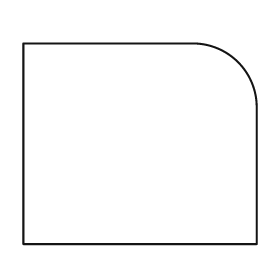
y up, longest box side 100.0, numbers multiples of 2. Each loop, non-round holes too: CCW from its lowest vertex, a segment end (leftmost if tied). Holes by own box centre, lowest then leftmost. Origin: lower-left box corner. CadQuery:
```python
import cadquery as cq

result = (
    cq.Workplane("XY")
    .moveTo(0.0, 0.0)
    .lineTo(100.0, 0.0)
    .lineTo(100.0, 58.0)
    .threePointArc((92.0, 78.0), (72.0, 86.0))
    .lineTo(0.0, 86.0)
    .close()
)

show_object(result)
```